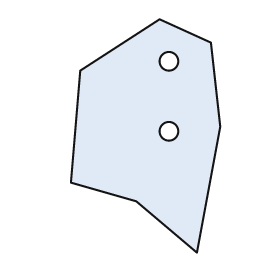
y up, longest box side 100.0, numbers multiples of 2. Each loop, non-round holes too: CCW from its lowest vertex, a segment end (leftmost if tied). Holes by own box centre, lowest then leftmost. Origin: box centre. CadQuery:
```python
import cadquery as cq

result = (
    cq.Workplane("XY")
    .moveTo(22.0, -50.0)
    .lineTo(32.0, 4.0)
    .lineTo(28.0, 40.0)
    .lineTo(6.0, 50.0)
    .lineTo(-28.0, 28.0)
    .lineTo(-32.0, -20.0)
    .lineTo(-4.0, -28.0)
    .close()
    .moveTo(10.0, 2.0)
    .circle(4.0)
    .moveTo(10.0, 32.0)
    .circle(4.0)
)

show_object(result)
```